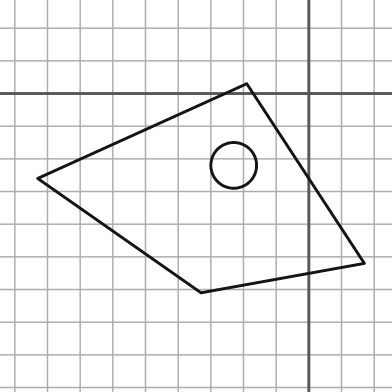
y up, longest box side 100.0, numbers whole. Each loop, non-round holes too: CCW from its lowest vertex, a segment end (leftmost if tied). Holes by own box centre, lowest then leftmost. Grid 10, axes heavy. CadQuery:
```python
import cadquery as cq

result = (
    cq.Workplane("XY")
    .moveTo(-33.0, -61.0)
    .lineTo(17.0, -52.0)
    .lineTo(-19.0, 3.0)
    .lineTo(-83.0, -26.0)
    .close()
    .moveTo(-23.0, -22.0)
    .circle(7.0)
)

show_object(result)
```